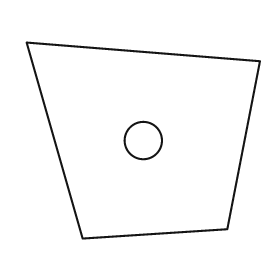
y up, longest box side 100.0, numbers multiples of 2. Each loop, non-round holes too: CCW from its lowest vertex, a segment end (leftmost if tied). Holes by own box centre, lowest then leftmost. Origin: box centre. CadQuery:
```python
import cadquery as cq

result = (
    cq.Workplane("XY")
    .moveTo(-26.0, -42.0)
    .lineTo(36.0, -38.0)
    .lineTo(50.0, 34.0)
    .lineTo(-50.0, 42.0)
    .close()
    .moveTo(0.0, 0.0)
    .circle(8.0)
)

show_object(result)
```